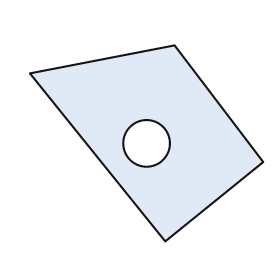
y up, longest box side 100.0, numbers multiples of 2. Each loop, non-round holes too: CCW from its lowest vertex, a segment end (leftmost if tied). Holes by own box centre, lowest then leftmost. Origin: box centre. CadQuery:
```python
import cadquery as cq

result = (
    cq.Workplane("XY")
    .moveTo(8.0, -42.0)
    .lineTo(50.0, -8.0)
    .lineTo(12.0, 42.0)
    .lineTo(-50.0, 30.0)
    .close()
    .moveTo(0.0, 0.0)
    .circle(10.0)
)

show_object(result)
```